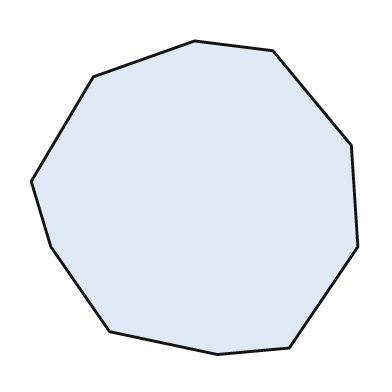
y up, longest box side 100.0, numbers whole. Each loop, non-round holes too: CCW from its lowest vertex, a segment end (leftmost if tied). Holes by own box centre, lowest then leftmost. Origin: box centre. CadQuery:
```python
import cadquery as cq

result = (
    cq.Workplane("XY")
    .moveTo(7.0, -48.0)
    .lineTo(29.0, -46.0)
    .lineTo(50.0, -15.0)
    .lineTo(48.0, 16.0)
    .lineTo(24.0, 45.0)
    .lineTo(0.0, 48.0)
    .lineTo(-31.0, 37.0)
    .lineTo(-50.0, 5.0)
    .lineTo(-44.0, -15.0)
    .lineTo(-26.0, -41.0)
    .close()
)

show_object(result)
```